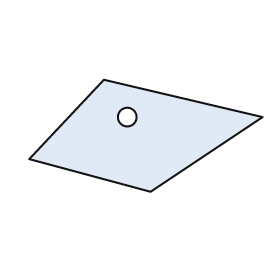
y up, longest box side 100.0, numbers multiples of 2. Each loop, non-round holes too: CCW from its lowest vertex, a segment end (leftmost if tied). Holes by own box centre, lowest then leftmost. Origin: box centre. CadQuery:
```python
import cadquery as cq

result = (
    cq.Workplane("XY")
    .moveTo(2.0, -24.0)
    .lineTo(50.0, 8.0)
    .lineTo(-18.0, 24.0)
    .lineTo(-50.0, -10.0)
    .close()
    .moveTo(-8.0, 8.0)
    .circle(4.0)
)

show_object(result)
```